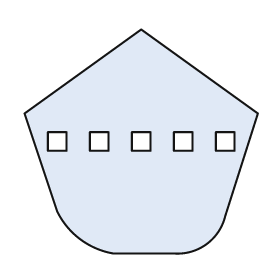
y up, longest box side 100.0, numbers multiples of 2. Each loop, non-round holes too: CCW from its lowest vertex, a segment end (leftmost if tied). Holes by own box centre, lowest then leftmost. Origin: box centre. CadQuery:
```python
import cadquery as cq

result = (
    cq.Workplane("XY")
    .moveTo(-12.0, -48.0)
    .lineTo(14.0, -48.0)
    .threePointArc((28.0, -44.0), (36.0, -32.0))
    .lineTo(50.0, 12.0)
    .lineTo(0.0, 48.0)
    .lineTo(-50.0, 12.0)
    .lineTo(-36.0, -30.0)
    .threePointArc((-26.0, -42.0), (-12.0, -48.0))
    .close()
    .moveTo(-40.0, -4.0)
    .lineTo(-32.0, -4.0)
    .lineTo(-32.0, 4.0)
    .lineTo(-40.0, 4.0)
    .close()
    .moveTo(-22.0, -4.0)
    .lineTo(-14.0, -4.0)
    .lineTo(-14.0, 4.0)
    .lineTo(-22.0, 4.0)
    .close()
    .moveTo(-4.0, -4.0)
    .lineTo(4.0, -4.0)
    .lineTo(4.0, 4.0)
    .lineTo(-4.0, 4.0)
    .close()
    .moveTo(14.0, -4.0)
    .lineTo(22.0, -4.0)
    .lineTo(22.0, 4.0)
    .lineTo(14.0, 4.0)
    .close()
    .moveTo(32.0, -4.0)
    .lineTo(40.0, -4.0)
    .lineTo(40.0, 4.0)
    .lineTo(32.0, 4.0)
    .close()
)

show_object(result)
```